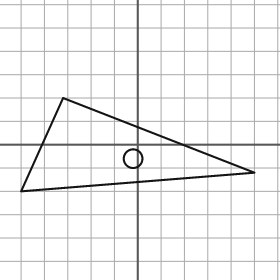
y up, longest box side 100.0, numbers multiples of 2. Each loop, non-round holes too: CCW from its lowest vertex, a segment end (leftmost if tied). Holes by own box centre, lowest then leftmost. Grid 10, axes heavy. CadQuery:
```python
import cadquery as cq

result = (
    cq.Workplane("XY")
    .moveTo(-50.0, -20.0)
    .lineTo(50.0, -12.0)
    .lineTo(-32.0, 20.0)
    .close()
    .moveTo(-2.0, -6.0)
    .circle(4.0)
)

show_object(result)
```